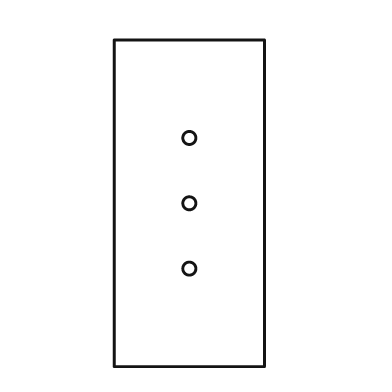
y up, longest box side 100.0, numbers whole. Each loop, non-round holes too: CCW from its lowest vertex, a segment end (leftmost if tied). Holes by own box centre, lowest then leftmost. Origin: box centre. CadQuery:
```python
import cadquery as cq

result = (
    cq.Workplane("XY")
    .moveTo(-23.0, -50.0)
    .lineTo(23.0, -50.0)
    .lineTo(23.0, 50.0)
    .lineTo(-23.0, 50.0)
    .close()
    .moveTo(0.0, -20.0)
    .circle(2.0)
    .moveTo(0.0, 0.0)
    .circle(2.0)
    .moveTo(0.0, 20.0)
    .circle(2.0)
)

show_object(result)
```